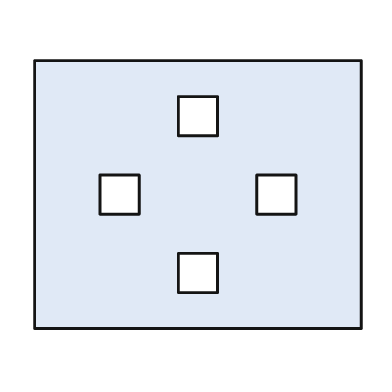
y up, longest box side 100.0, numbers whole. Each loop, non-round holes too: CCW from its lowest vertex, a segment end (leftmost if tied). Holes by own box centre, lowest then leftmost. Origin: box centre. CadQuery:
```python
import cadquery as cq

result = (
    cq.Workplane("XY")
    .moveTo(-50.0, -41.0)
    .lineTo(50.0, -41.0)
    .lineTo(50.0, 41.0)
    .lineTo(-50.0, 41.0)
    .close()
    .moveTo(-6.0, -30.0)
    .lineTo(6.0, -30.0)
    .lineTo(6.0, -18.0)
    .lineTo(-6.0, -18.0)
    .close()
    .moveTo(-30.0, -6.0)
    .lineTo(-18.0, -6.0)
    .lineTo(-18.0, 6.0)
    .lineTo(-30.0, 6.0)
    .close()
    .moveTo(18.0, -6.0)
    .lineTo(30.0, -6.0)
    .lineTo(30.0, 6.0)
    .lineTo(18.0, 6.0)
    .close()
    .moveTo(-6.0, 18.0)
    .lineTo(6.0, 18.0)
    .lineTo(6.0, 30.0)
    .lineTo(-6.0, 30.0)
    .close()
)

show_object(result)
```